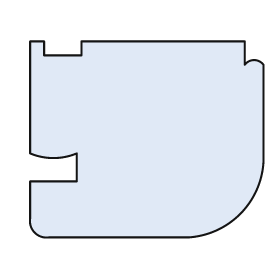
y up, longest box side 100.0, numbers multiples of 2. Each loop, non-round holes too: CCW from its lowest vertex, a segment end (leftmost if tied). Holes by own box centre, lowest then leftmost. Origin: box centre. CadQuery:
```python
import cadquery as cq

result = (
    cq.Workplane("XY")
    .moveTo(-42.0, -42.0)
    .lineTo(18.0, -42.0)
    .threePointArc((40.0, -32.0), (50.0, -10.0))
    .lineTo(50.0, 32.0)
    .threePointArc((46.0, 34.0), (42.0, 32.0))
    .lineTo(42.0, 42.0)
    .lineTo(-28.0, 42.0)
    .lineTo(-28.0, 36.0)
    .lineTo(-44.0, 36.0)
    .lineTo(-44.0, 42.0)
    .lineTo(-50.0, 42.0)
    .lineTo(-50.0, -6.0)
    .threePointArc((-40.0, -8.0), (-30.0, -6.0))
    .lineTo(-30.0, -18.0)
    .lineTo(-50.0, -18.0)
    .lineTo(-50.0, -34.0)
    .threePointArc((-48.0, -40.0), (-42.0, -42.0))
    .close()
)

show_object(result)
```